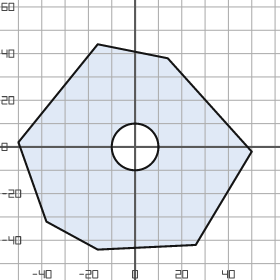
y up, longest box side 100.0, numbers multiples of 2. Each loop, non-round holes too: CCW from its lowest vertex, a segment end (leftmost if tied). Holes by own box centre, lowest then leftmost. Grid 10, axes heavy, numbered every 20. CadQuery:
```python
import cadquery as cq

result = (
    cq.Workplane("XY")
    .moveTo(-16.0, -44.0)
    .lineTo(26.0, -42.0)
    .lineTo(50.0, -2.0)
    .lineTo(14.0, 38.0)
    .lineTo(-16.0, 44.0)
    .lineTo(-50.0, 2.0)
    .lineTo(-38.0, -32.0)
    .close()
    .moveTo(0.0, 0.0)
    .circle(10.0)
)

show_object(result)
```